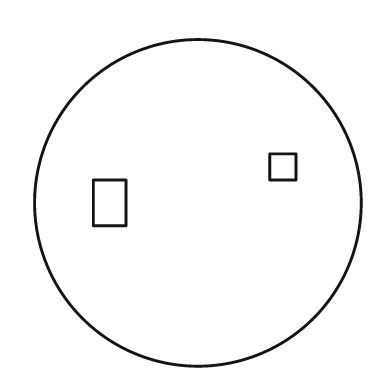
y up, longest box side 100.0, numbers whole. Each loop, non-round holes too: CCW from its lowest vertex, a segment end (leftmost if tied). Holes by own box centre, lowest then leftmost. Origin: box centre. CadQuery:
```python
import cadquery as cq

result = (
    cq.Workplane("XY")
    .moveTo(0.0, 0.0)
    .circle(50.0)
    .moveTo(-32.0, -7.0)
    .lineTo(-22.0, -7.0)
    .lineTo(-22.0, 7.0)
    .lineTo(-32.0, 7.0)
    .close()
    .moveTo(22.0, 7.0)
    .lineTo(30.0, 7.0)
    .lineTo(30.0, 15.0)
    .lineTo(22.0, 15.0)
    .close()
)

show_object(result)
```